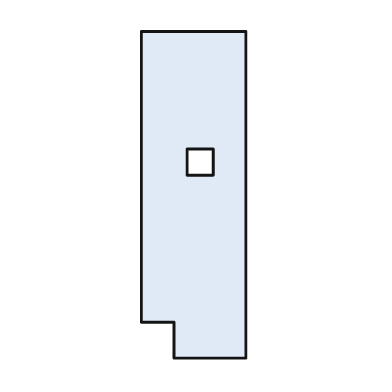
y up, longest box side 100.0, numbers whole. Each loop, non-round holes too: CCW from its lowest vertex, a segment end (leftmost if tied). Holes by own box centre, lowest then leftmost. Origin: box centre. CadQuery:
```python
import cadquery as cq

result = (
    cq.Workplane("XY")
    .moveTo(-6.0, -50.0)
    .lineTo(16.0, -50.0)
    .lineTo(16.0, 50.0)
    .lineTo(-16.0, 50.0)
    .lineTo(-16.0, -39.0)
    .lineTo(-6.0, -39.0)
    .close()
    .moveTo(-2.0, 6.0)
    .lineTo(6.0, 6.0)
    .lineTo(6.0, 14.0)
    .lineTo(-2.0, 14.0)
    .close()
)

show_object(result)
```